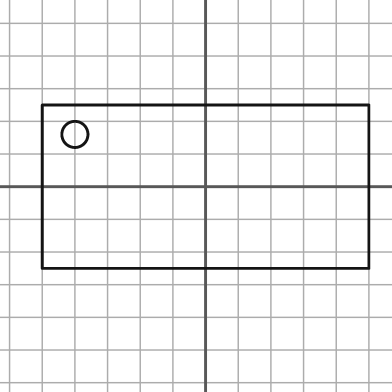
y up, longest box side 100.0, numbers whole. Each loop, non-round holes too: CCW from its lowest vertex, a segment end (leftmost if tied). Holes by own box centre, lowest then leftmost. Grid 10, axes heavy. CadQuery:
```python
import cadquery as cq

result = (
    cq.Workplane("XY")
    .moveTo(-50.0, -25.0)
    .lineTo(50.0, -25.0)
    .lineTo(50.0, 25.0)
    .lineTo(-50.0, 25.0)
    .close()
    .moveTo(-40.0, 16.0)
    .circle(4.0)
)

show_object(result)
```